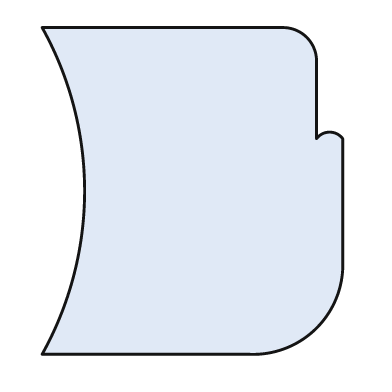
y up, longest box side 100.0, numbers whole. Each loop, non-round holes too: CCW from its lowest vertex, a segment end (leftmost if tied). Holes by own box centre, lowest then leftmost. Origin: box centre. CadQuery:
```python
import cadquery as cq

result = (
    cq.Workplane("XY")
    .moveTo(-46.0, -50.0)
    .lineTo(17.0, -50.0)
    .threePointArc((38.0, -42.0), (46.0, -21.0))
    .lineTo(46.0, 16.0)
    .threePointArc((42.0, 18.0), (38.0, 16.0))
    .lineTo(38.0, 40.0)
    .threePointArc((35.0, 47.0), (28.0, 50.0))
    .lineTo(-46.0, 50.0)
    .threePointArc((-33.0, 0.0), (-46.0, -50.0))
    .close()
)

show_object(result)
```